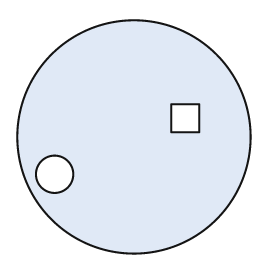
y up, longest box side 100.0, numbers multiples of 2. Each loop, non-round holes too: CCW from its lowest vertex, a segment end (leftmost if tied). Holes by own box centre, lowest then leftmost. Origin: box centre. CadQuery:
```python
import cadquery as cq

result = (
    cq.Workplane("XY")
    .moveTo(0.0, 0.0)
    .circle(50.0)
    .moveTo(-34.0, -16.0)
    .circle(8.0)
    .moveTo(16.0, 2.0)
    .lineTo(28.0, 2.0)
    .lineTo(28.0, 14.0)
    .lineTo(16.0, 14.0)
    .close()
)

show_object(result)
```